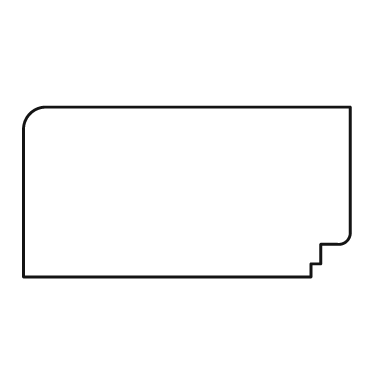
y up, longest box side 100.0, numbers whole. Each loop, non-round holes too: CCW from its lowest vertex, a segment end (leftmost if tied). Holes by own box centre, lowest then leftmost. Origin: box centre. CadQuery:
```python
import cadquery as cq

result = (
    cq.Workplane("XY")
    .moveTo(-50.0, -26.0)
    .lineTo(38.0, -26.0)
    .lineTo(38.0, -22.0)
    .lineTo(41.0, -22.0)
    .lineTo(41.0, -16.0)
    .lineTo(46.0, -16.0)
    .threePointArc((49.0, -15.0), (50.0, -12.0))
    .lineTo(50.0, 26.0)
    .lineTo(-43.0, 26.0)
    .threePointArc((-48.0, 24.0), (-50.0, 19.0))
    .close()
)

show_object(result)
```